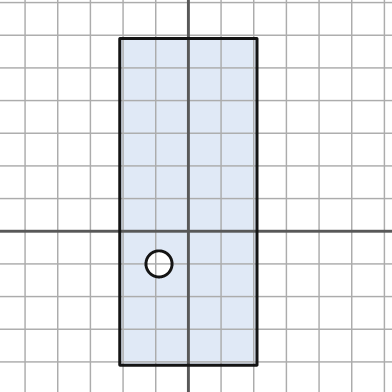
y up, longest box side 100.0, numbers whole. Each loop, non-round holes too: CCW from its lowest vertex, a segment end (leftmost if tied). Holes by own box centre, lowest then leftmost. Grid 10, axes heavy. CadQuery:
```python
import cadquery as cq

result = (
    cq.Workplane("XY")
    .moveTo(-21.0, -41.0)
    .lineTo(21.0, -41.0)
    .lineTo(21.0, 59.0)
    .lineTo(-21.0, 59.0)
    .close()
    .moveTo(-9.0, -10.0)
    .circle(4.0)
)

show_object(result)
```